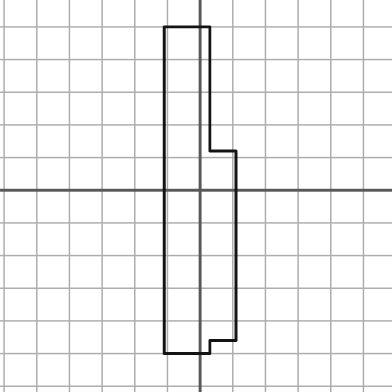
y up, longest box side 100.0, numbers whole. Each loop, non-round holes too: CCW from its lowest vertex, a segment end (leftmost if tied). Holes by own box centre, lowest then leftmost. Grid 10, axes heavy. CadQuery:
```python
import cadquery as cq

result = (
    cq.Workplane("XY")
    .moveTo(-11.0, -50.0)
    .lineTo(3.0, -50.0)
    .lineTo(3.0, -46.0)
    .lineTo(11.0, -46.0)
    .lineTo(11.0, 12.0)
    .lineTo(3.0, 12.0)
    .lineTo(3.0, 50.0)
    .lineTo(-11.0, 50.0)
    .close()
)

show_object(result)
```